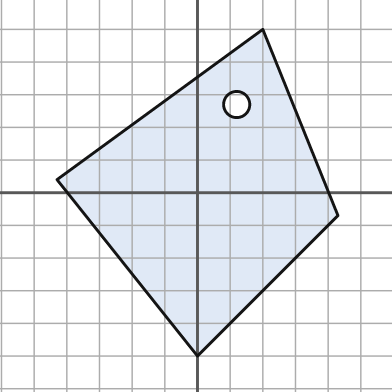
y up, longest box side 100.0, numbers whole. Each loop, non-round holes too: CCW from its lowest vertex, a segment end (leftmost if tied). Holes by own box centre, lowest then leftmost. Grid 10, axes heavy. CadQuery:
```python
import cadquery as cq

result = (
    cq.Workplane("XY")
    .moveTo(0.0, -50.0)
    .lineTo(43.0, -7.0)
    .lineTo(20.0, 50.0)
    .lineTo(-43.0, 4.0)
    .close()
    .moveTo(12.0, 27.0)
    .circle(4.0)
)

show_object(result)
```